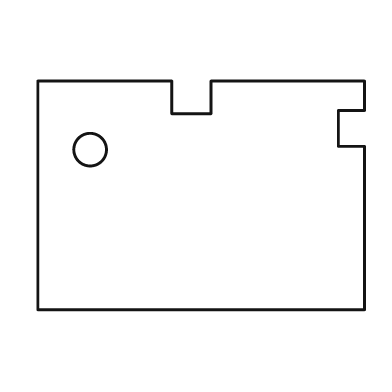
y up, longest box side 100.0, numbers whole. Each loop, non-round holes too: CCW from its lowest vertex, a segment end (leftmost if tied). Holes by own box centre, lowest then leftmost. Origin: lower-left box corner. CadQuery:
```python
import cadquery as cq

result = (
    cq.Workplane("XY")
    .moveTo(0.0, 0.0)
    .lineTo(100.0, 0.0)
    .lineTo(100.0, 50.0)
    .lineTo(92.0, 50.0)
    .lineTo(92.0, 61.0)
    .lineTo(100.0, 61.0)
    .lineTo(100.0, 70.0)
    .lineTo(53.0, 70.0)
    .lineTo(53.0, 60.0)
    .lineTo(41.0, 60.0)
    .lineTo(41.0, 70.0)
    .lineTo(0.0, 70.0)
    .close()
    .moveTo(16.0, 49.0)
    .circle(5.0)
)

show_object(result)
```